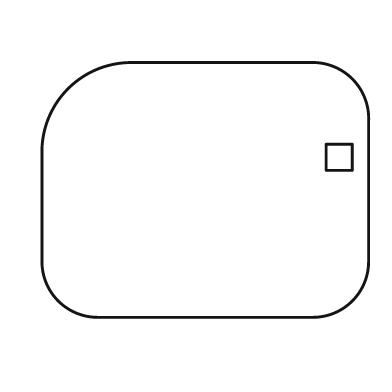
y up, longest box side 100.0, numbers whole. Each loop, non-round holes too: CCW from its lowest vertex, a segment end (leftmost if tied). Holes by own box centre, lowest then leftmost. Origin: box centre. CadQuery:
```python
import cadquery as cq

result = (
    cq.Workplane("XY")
    .moveTo(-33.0, -39.0)
    .lineTo(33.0, -39.0)
    .threePointArc((45.0, -34.0), (50.0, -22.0))
    .lineTo(50.0, 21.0)
    .threePointArc((45.0, 34.0), (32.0, 39.0))
    .lineTo(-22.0, 39.0)
    .threePointArc((-42.0, 31.0), (-50.0, 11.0))
    .lineTo(-50.0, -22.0)
    .threePointArc((-45.0, -34.0), (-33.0, -39.0))
    .close()
    .moveTo(37.0, 6.0)
    .lineTo(45.0, 6.0)
    .lineTo(45.0, 14.0)
    .lineTo(37.0, 14.0)
    .close()
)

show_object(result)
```